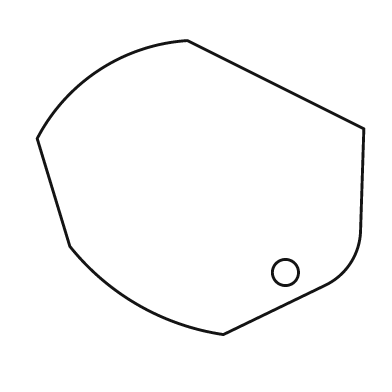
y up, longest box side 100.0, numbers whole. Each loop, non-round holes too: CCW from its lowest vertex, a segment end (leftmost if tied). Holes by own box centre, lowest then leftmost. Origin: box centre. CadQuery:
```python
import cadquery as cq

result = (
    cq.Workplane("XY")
    .moveTo(7.0, -45.0)
    .lineTo(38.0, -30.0)
    .threePointArc((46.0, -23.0), (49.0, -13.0))
    .lineTo(50.0, 18.0)
    .lineTo(-4.0, 45.0)
    .threePointArc((-31.0, 36.0), (-50.0, 15.0))
    .lineTo(-40.0, -18.0)
    .threePointArc((-19.0, -36.0), (7.0, -45.0))
    .close()
    .moveTo(26.0, -26.0)
    .circle(4.0)
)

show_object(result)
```